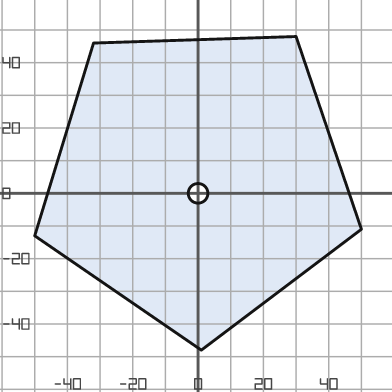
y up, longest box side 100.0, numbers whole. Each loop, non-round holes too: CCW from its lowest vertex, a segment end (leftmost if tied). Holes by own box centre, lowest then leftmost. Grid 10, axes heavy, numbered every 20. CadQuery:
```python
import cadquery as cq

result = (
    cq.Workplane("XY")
    .moveTo(1.0, -48.0)
    .lineTo(50.0, -11.0)
    .lineTo(30.0, 48.0)
    .lineTo(-32.0, 46.0)
    .lineTo(-50.0, -13.0)
    .close()
    .moveTo(0.0, 0.0)
    .circle(3.0)
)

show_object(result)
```